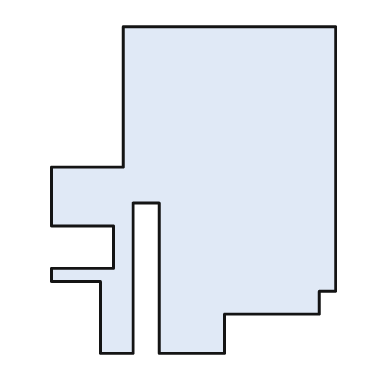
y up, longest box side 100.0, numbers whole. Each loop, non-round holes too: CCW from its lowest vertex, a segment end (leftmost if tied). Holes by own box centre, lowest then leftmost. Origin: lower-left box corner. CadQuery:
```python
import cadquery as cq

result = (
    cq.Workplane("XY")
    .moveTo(15.0, 0.0)
    .lineTo(25.0, 0.0)
    .lineTo(25.0, 46.0)
    .lineTo(33.0, 46.0)
    .lineTo(33.0, 0.0)
    .lineTo(53.0, 0.0)
    .lineTo(53.0, 12.0)
    .lineTo(82.0, 12.0)
    .lineTo(82.0, 19.0)
    .lineTo(87.0, 19.0)
    .lineTo(87.0, 100.0)
    .lineTo(22.0, 100.0)
    .lineTo(22.0, 57.0)
    .lineTo(0.0, 57.0)
    .lineTo(0.0, 39.0)
    .lineTo(19.0, 39.0)
    .lineTo(19.0, 26.0)
    .lineTo(0.0, 26.0)
    .lineTo(0.0, 22.0)
    .lineTo(15.0, 22.0)
    .close()
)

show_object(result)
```